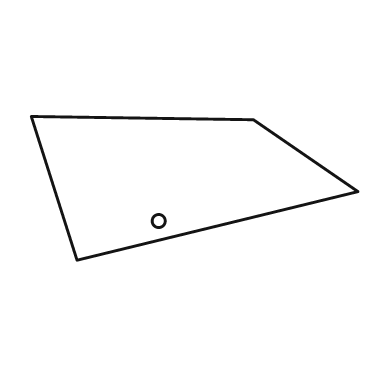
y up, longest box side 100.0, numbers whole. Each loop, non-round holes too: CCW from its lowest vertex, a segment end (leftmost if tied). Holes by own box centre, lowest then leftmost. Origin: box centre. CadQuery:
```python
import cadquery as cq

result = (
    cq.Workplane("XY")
    .moveTo(-36.0, -22.0)
    .lineTo(50.0, -1.0)
    .lineTo(18.0, 21.0)
    .lineTo(-50.0, 22.0)
    .close()
    .moveTo(-11.0, -10.0)
    .circle(2.0)
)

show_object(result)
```